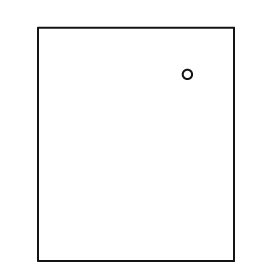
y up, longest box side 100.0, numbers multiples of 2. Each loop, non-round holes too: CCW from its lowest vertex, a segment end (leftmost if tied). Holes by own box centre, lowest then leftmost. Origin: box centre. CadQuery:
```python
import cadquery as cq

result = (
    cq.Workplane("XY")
    .moveTo(-42.0, -50.0)
    .lineTo(42.0, -50.0)
    .lineTo(42.0, 50.0)
    .lineTo(-42.0, 50.0)
    .close()
    .moveTo(22.0, 30.0)
    .circle(2.0)
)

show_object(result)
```